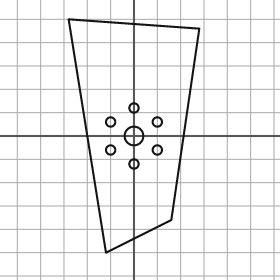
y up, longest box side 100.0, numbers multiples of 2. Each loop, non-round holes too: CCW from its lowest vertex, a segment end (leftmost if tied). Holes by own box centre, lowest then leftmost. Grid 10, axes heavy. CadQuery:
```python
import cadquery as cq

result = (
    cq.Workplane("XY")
    .moveTo(-12.0, -50.0)
    .lineTo(16.0, -36.0)
    .lineTo(28.0, 46.0)
    .lineTo(-28.0, 50.0)
    .close()
    .moveTo(0.0, -12.0)
    .circle(2.0)
    .moveTo(-10.0, -6.0)
    .circle(2.0)
    .moveTo(10.0, -6.0)
    .circle(2.0)
    .moveTo(0.0, 0.0)
    .circle(4.0)
    .moveTo(-10.0, 6.0)
    .circle(2.0)
    .moveTo(10.0, 6.0)
    .circle(2.0)
    .moveTo(0.0, 12.0)
    .circle(2.0)
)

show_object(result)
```